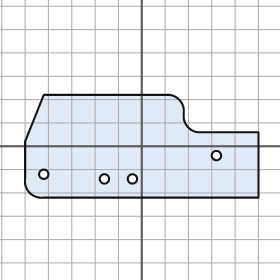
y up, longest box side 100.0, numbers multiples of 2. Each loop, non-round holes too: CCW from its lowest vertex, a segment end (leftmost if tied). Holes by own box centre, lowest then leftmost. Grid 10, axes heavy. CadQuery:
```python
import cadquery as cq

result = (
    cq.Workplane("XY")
    .moveTo(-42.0, -22.0)
    .lineTo(50.0, -22.0)
    .lineTo(50.0, 6.0)
    .lineTo(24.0, 6.0)
    .threePointArc((20.0, 8.0), (18.0, 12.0))
    .lineTo(18.0, 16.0)
    .threePointArc((16.0, 20.0), (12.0, 22.0))
    .lineTo(-42.0, 22.0)
    .lineTo(-50.0, 2.0)
    .lineTo(-50.0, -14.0)
    .threePointArc((-48.0, -20.0), (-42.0, -22.0))
    .close()
    .moveTo(-16.0, -14.0)
    .circle(2.0)
    .moveTo(-4.0, -14.0)
    .circle(2.0)
    .moveTo(-42.0, -12.0)
    .circle(2.0)
    .moveTo(32.0, -4.0)
    .circle(2.0)
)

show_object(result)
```